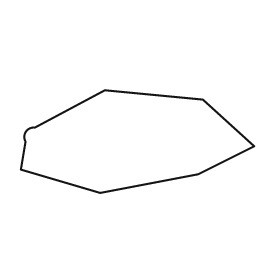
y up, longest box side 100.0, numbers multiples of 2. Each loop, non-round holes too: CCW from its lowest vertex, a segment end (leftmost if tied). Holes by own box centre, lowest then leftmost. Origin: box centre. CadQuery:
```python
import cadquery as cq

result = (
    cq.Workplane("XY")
    .moveTo(-16.0, -22.0)
    .lineTo(26.0, -14.0)
    .lineTo(50.0, -2.0)
    .lineTo(28.0, 18.0)
    .lineTo(-14.0, 22.0)
    .lineTo(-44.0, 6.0)
    .threePointArc((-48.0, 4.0), (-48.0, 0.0))
    .lineTo(-50.0, -12.0)
    .close()
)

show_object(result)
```